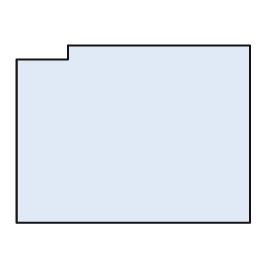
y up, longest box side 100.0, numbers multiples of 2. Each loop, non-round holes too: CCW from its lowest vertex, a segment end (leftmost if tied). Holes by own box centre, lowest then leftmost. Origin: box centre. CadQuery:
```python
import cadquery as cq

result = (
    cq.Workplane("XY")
    .moveTo(-50.0, -38.0)
    .lineTo(50.0, -38.0)
    .lineTo(50.0, 38.0)
    .lineTo(-28.0, 38.0)
    .lineTo(-28.0, 32.0)
    .lineTo(-50.0, 32.0)
    .close()
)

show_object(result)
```